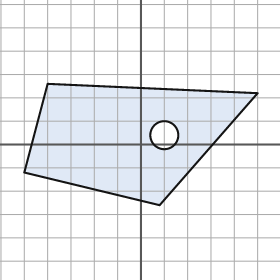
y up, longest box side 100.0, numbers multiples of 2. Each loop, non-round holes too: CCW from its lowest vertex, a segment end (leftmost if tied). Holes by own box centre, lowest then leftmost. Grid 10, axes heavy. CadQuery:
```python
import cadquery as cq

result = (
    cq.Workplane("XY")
    .moveTo(8.0, -26.0)
    .lineTo(50.0, 22.0)
    .lineTo(-40.0, 26.0)
    .lineTo(-50.0, -12.0)
    .close()
    .moveTo(10.0, 4.0)
    .circle(6.0)
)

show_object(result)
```